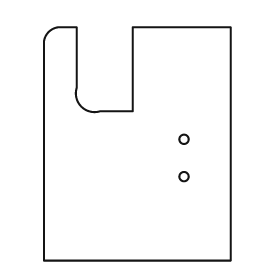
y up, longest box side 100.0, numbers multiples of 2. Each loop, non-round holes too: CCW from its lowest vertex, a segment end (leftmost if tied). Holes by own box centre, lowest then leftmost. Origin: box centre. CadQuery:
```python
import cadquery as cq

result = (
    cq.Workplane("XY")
    .moveTo(-40.0, -50.0)
    .lineTo(40.0, -50.0)
    .lineTo(40.0, 50.0)
    .lineTo(-2.0, 50.0)
    .lineTo(-2.0, 14.0)
    .lineTo(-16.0, 14.0)
    .threePointArc((-24.0, 16.0), (-26.0, 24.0))
    .lineTo(-26.0, 50.0)
    .lineTo(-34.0, 50.0)
    .threePointArc((-38.0, 48.0), (-40.0, 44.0))
    .close()
    .moveTo(20.0, -14.0)
    .circle(2.0)
    .moveTo(20.0, 2.0)
    .circle(2.0)
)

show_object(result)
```